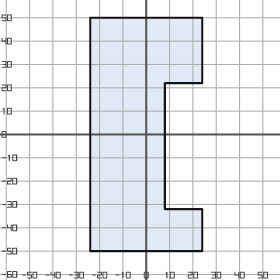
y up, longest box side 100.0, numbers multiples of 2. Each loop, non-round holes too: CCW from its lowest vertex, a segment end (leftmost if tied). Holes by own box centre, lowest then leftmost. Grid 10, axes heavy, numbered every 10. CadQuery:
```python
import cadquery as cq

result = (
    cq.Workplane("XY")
    .moveTo(-24.0, -50.0)
    .lineTo(24.0, -50.0)
    .lineTo(24.0, -32.0)
    .lineTo(8.0, -32.0)
    .lineTo(8.0, 22.0)
    .lineTo(24.0, 22.0)
    .lineTo(24.0, 50.0)
    .lineTo(-24.0, 50.0)
    .close()
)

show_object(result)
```